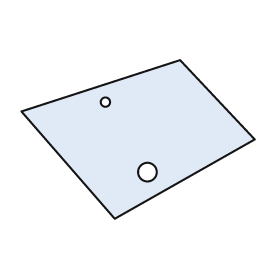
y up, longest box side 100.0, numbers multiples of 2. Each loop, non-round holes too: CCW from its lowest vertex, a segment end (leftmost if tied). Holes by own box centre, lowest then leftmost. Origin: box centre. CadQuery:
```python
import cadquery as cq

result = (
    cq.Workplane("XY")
    .moveTo(-10.0, -34.0)
    .lineTo(50.0, 0.0)
    .lineTo(18.0, 34.0)
    .lineTo(-50.0, 12.0)
    .close()
    .moveTo(4.0, -14.0)
    .circle(4.0)
    .moveTo(-14.0, 16.0)
    .circle(2.0)
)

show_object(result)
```